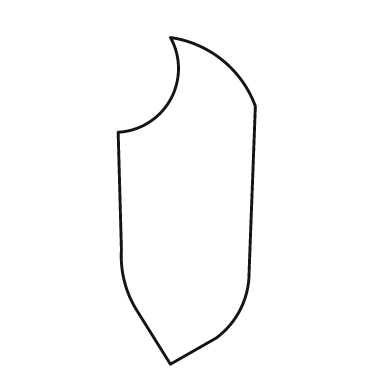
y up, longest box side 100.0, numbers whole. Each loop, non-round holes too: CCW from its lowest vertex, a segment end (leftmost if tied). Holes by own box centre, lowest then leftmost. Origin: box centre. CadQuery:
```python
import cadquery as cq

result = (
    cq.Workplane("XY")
    .moveTo(-5.0, -50.0)
    .lineTo(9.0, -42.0)
    .threePointArc((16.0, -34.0), (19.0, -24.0))
    .lineTo(21.0, 29.0)
    .threePointArc((11.0, 43.0), (-5.0, 50.0))
    .threePointArc((-5.0, 31.0), (-21.0, 21.0))
    .lineTo(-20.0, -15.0)
    .threePointArc((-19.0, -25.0), (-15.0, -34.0))
    .close()
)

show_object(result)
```